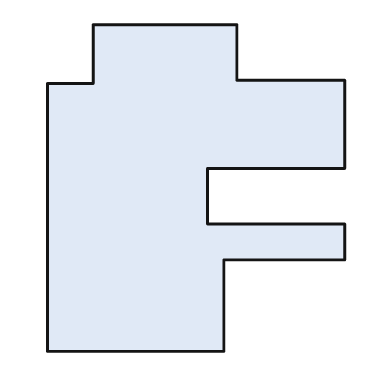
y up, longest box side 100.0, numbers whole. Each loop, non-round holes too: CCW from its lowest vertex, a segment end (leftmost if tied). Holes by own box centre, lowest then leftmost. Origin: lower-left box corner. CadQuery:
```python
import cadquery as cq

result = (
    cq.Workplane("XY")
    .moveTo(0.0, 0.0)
    .lineTo(54.0, 0.0)
    .lineTo(54.0, 28.0)
    .lineTo(91.0, 28.0)
    .lineTo(91.0, 39.0)
    .lineTo(49.0, 39.0)
    .lineTo(49.0, 56.0)
    .lineTo(91.0, 56.0)
    .lineTo(91.0, 83.0)
    .lineTo(58.0, 83.0)
    .lineTo(58.0, 100.0)
    .lineTo(14.0, 100.0)
    .lineTo(14.0, 82.0)
    .lineTo(0.0, 82.0)
    .close()
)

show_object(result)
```